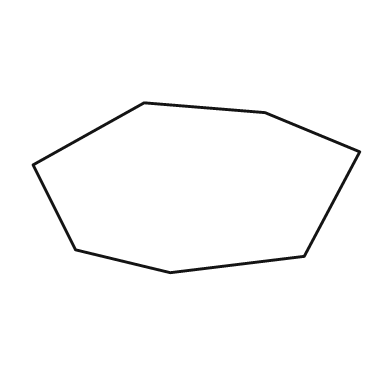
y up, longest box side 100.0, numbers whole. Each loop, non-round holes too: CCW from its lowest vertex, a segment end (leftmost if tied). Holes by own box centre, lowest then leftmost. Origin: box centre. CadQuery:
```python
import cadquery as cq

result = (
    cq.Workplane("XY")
    .moveTo(-8.0, -26.0)
    .lineTo(33.0, -21.0)
    .lineTo(50.0, 11.0)
    .lineTo(21.0, 23.0)
    .lineTo(-16.0, 26.0)
    .lineTo(-50.0, 7.0)
    .lineTo(-37.0, -19.0)
    .close()
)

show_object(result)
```